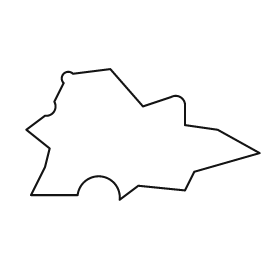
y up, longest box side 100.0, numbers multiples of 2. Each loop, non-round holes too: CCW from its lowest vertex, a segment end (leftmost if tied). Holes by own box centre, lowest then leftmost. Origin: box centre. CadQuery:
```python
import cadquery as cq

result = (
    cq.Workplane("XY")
    .moveTo(-10.0, -28.0)
    .lineTo(-2.0, -22.0)
    .lineTo(18.0, -24.0)
    .lineTo(22.0, -16.0)
    .lineTo(50.0, -8.0)
    .lineTo(32.0, 2.0)
    .lineTo(18.0, 4.0)
    .lineTo(18.0, 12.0)
    .threePointArc((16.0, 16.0), (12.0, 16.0))
    .lineTo(0.0, 12.0)
    .lineTo(-14.0, 28.0)
    .lineTo(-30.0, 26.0)
    .threePointArc((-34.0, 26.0), (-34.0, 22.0))
    .lineTo(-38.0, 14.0)
    .threePointArc((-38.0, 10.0), (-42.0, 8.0))
    .lineTo(-50.0, 2.0)
    .lineTo(-40.0, -6.0)
    .lineTo(-42.0, -14.0)
    .lineTo(-48.0, -26.0)
    .lineTo(-28.0, -26.0)
    .threePointArc((-18.0, -18.0), (-10.0, -28.0))
    .close()
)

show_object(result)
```